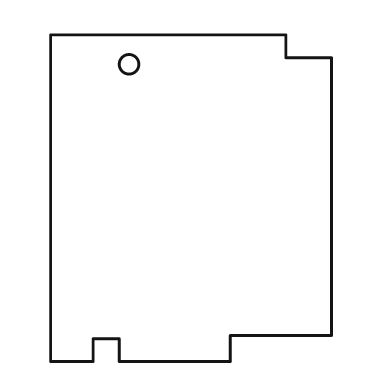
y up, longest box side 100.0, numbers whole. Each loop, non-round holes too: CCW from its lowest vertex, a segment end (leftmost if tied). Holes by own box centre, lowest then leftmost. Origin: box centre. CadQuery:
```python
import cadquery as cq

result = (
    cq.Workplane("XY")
    .moveTo(-43.0, -50.0)
    .lineTo(-30.0, -50.0)
    .lineTo(-30.0, -43.0)
    .lineTo(-22.0, -43.0)
    .lineTo(-22.0, -50.0)
    .lineTo(12.0, -50.0)
    .lineTo(12.0, -42.0)
    .lineTo(43.0, -42.0)
    .lineTo(43.0, 43.0)
    .lineTo(29.0, 43.0)
    .lineTo(29.0, 50.0)
    .lineTo(-43.0, 50.0)
    .close()
    .moveTo(-19.0, 41.0)
    .circle(3.0)
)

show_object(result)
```